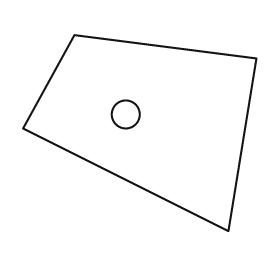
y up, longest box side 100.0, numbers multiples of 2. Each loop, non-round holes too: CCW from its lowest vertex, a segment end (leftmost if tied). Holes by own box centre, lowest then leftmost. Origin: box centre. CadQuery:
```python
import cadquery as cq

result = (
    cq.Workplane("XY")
    .moveTo(38.0, -42.0)
    .lineTo(50.0, 32.0)
    .lineTo(-28.0, 42.0)
    .lineTo(-50.0, 2.0)
    .close()
    .moveTo(-6.0, 8.0)
    .circle(6.0)
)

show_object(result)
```